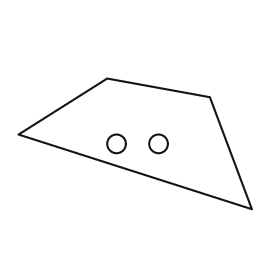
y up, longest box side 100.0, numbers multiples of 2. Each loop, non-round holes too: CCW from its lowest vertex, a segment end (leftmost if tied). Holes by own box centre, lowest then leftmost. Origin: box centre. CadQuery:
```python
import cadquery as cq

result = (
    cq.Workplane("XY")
    .moveTo(50.0, -28.0)
    .lineTo(32.0, 20.0)
    .lineTo(-12.0, 28.0)
    .lineTo(-50.0, 4.0)
    .close()
    .moveTo(-8.0, 0.0)
    .circle(4.0)
    .moveTo(10.0, 0.0)
    .circle(4.0)
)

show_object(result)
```